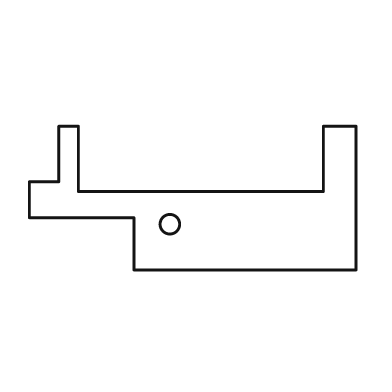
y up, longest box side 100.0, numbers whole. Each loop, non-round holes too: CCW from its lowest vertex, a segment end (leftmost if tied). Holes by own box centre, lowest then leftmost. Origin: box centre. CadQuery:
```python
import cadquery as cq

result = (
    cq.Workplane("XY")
    .moveTo(-18.0, -22.0)
    .lineTo(50.0, -22.0)
    .lineTo(50.0, 22.0)
    .lineTo(40.0, 22.0)
    .lineTo(40.0, 2.0)
    .lineTo(-35.0, 2.0)
    .lineTo(-35.0, 22.0)
    .lineTo(-41.0, 22.0)
    .lineTo(-41.0, 5.0)
    .lineTo(-50.0, 5.0)
    .lineTo(-50.0, -6.0)
    .lineTo(-18.0, -6.0)
    .close()
    .moveTo(-7.0, -8.0)
    .circle(3.0)
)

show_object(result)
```